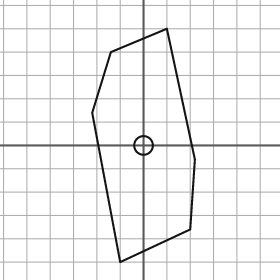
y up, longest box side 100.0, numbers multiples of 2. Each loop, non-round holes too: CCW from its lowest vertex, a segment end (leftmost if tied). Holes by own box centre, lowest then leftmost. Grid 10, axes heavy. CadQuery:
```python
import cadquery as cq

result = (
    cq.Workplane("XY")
    .moveTo(-10.0, -50.0)
    .lineTo(20.0, -36.0)
    .lineTo(22.0, -6.0)
    .lineTo(10.0, 50.0)
    .lineTo(-14.0, 40.0)
    .lineTo(-22.0, 14.0)
    .close()
    .moveTo(0.0, 0.0)
    .circle(4.0)
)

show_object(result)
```